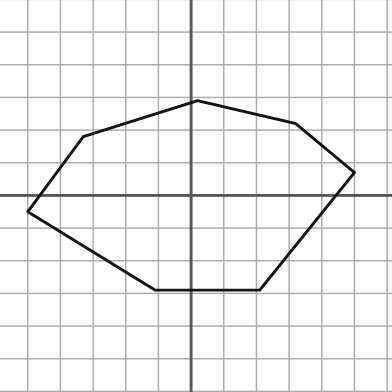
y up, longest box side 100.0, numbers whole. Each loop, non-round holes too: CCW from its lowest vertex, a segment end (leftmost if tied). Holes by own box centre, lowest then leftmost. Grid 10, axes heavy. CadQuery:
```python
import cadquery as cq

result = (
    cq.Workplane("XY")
    .moveTo(-11.0, -29.0)
    .lineTo(21.0, -29.0)
    .lineTo(50.0, 7.0)
    .lineTo(32.0, 22.0)
    .lineTo(2.0, 29.0)
    .lineTo(-33.0, 18.0)
    .lineTo(-50.0, -5.0)
    .close()
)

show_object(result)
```